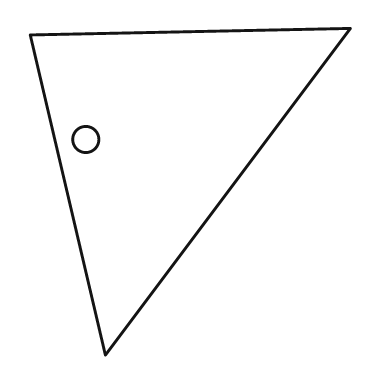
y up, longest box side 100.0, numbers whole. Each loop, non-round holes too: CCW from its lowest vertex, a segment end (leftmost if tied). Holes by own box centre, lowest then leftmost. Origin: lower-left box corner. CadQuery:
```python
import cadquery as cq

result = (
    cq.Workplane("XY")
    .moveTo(23.0, 0.0)
    .lineTo(98.0, 100.0)
    .lineTo(0.0, 98.0)
    .close()
    .moveTo(17.0, 66.0)
    .circle(4.0)
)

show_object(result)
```